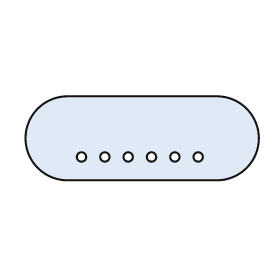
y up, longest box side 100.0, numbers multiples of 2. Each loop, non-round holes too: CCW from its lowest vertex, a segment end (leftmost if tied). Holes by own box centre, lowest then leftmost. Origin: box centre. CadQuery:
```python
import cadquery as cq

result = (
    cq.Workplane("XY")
    .moveTo(-32.0, -18.0)
    .lineTo(32.0, -18.0)
    .threePointArc((50.0, 0.0), (32.0, 18.0))
    .lineTo(-32.0, 18.0)
    .threePointArc((-50.0, 0.0), (-32.0, -18.0))
    .close()
    .moveTo(-26.0, -8.0)
    .circle(2.0)
    .moveTo(-16.0, -8.0)
    .circle(2.0)
    .moveTo(-6.0, -8.0)
    .circle(2.0)
    .moveTo(4.0, -8.0)
    .circle(2.0)
    .moveTo(14.0, -8.0)
    .circle(2.0)
    .moveTo(24.0, -8.0)
    .circle(2.0)
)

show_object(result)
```